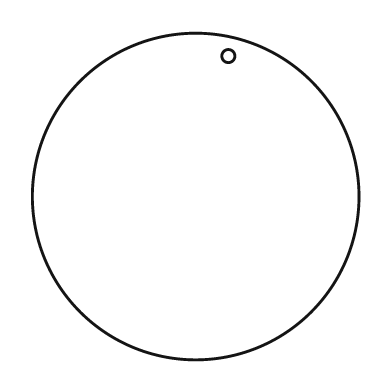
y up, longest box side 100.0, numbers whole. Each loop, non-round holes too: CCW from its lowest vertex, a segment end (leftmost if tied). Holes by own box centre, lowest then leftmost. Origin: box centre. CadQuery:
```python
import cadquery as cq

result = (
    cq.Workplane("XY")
    .moveTo(0.0, 0.0)
    .circle(50.0)
    .moveTo(10.0, 43.0)
    .circle(2.0)
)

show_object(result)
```